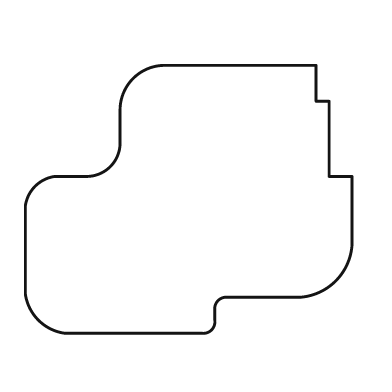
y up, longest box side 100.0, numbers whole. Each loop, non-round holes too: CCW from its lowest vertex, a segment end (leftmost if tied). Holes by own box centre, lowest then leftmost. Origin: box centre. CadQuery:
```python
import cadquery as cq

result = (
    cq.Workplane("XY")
    .moveTo(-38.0, -41.0)
    .lineTo(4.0, -41.0)
    .threePointArc((7.0, -40.0), (8.0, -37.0))
    .lineTo(8.0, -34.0)
    .threePointArc((9.0, -31.0), (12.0, -30.0))
    .lineTo(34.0, -30.0)
    .threePointArc((45.0, -25.0), (50.0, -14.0))
    .lineTo(50.0, 7.0)
    .lineTo(43.0, 7.0)
    .lineTo(43.0, 30.0)
    .lineTo(39.0, 30.0)
    .lineTo(39.0, 41.0)
    .lineTo(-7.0, 41.0)
    .threePointArc((-17.0, 37.0), (-21.0, 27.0))
    .lineTo(-21.0, 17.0)
    .threePointArc((-24.0, 10.0), (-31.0, 7.0))
    .lineTo(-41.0, 7.0)
    .threePointArc((-47.0, 4.0), (-50.0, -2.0))
    .lineTo(-50.0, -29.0)
    .threePointArc((-46.0, -37.0), (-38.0, -41.0))
    .close()
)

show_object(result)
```